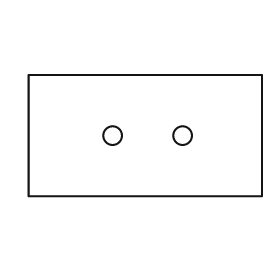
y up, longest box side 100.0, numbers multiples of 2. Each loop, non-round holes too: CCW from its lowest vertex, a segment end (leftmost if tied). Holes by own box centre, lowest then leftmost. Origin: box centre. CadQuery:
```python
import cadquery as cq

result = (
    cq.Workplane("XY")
    .moveTo(-50.0, -26.0)
    .lineTo(50.0, -26.0)
    .lineTo(50.0, 26.0)
    .lineTo(-50.0, 26.0)
    .close()
    .moveTo(-14.0, 0.0)
    .circle(4.0)
    .moveTo(16.0, 0.0)
    .circle(4.0)
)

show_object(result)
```